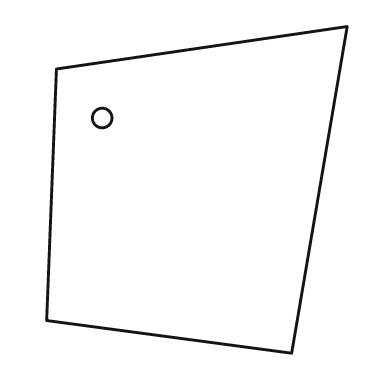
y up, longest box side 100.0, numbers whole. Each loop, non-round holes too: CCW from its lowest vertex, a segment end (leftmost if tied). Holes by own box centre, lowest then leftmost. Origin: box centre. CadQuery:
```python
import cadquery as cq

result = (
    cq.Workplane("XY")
    .moveTo(29.0, -50.0)
    .lineTo(46.0, 50.0)
    .lineTo(-43.0, 37.0)
    .lineTo(-46.0, -40.0)
    .close()
    .moveTo(-29.0, 22.0)
    .circle(3.0)
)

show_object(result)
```